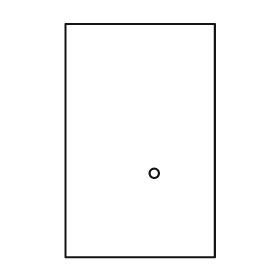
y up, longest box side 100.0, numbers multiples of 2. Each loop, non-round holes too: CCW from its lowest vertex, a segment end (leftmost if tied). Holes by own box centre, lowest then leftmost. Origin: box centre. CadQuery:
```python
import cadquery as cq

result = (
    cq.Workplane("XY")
    .moveTo(-32.0, -50.0)
    .lineTo(32.0, -50.0)
    .lineTo(32.0, 50.0)
    .lineTo(-32.0, 50.0)
    .close()
    .moveTo(6.0, -14.0)
    .circle(2.0)
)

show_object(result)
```